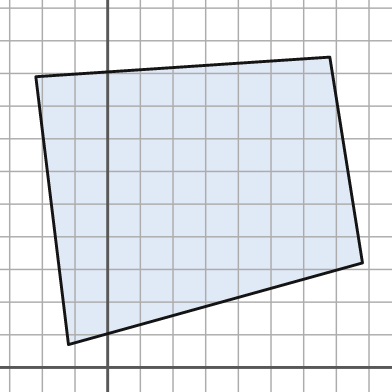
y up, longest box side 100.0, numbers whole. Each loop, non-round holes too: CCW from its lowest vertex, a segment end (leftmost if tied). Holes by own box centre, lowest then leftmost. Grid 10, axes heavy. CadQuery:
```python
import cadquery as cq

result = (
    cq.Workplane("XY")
    .moveTo(-12.0, 7.0)
    .lineTo(78.0, 32.0)
    .lineTo(68.0, 95.0)
    .lineTo(-22.0, 89.0)
    .close()
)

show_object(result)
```